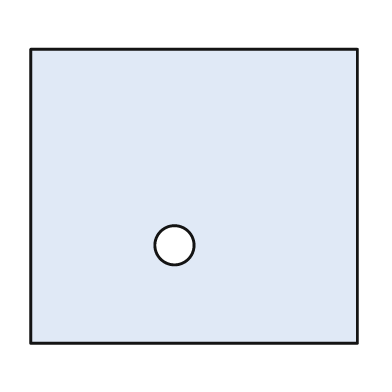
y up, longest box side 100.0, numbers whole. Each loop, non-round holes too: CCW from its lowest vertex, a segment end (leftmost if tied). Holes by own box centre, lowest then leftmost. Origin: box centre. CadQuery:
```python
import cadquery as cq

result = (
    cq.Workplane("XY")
    .moveTo(-50.0, -45.0)
    .lineTo(50.0, -45.0)
    .lineTo(50.0, 45.0)
    .lineTo(-50.0, 45.0)
    .close()
    .moveTo(-6.0, -15.0)
    .circle(6.0)
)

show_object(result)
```